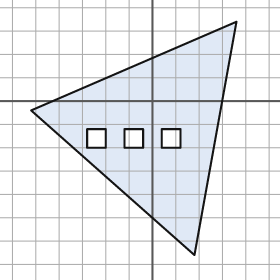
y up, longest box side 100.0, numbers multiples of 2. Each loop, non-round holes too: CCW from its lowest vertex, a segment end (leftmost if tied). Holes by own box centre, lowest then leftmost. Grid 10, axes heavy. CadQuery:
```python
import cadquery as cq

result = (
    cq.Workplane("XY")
    .moveTo(18.0, -66.0)
    .lineTo(36.0, 34.0)
    .lineTo(-52.0, -4.0)
    .close()
    .moveTo(-28.0, -20.0)
    .lineTo(-20.0, -20.0)
    .lineTo(-20.0, -12.0)
    .lineTo(-28.0, -12.0)
    .close()
    .moveTo(-12.0, -20.0)
    .lineTo(-4.0, -20.0)
    .lineTo(-4.0, -12.0)
    .lineTo(-12.0, -12.0)
    .close()
    .moveTo(4.0, -20.0)
    .lineTo(12.0, -20.0)
    .lineTo(12.0, -12.0)
    .lineTo(4.0, -12.0)
    .close()
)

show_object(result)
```